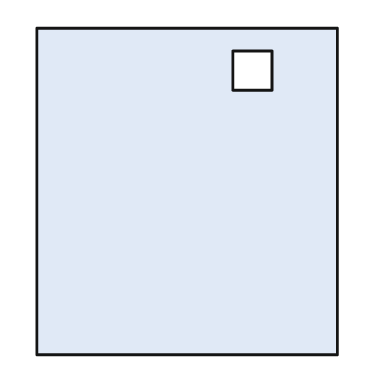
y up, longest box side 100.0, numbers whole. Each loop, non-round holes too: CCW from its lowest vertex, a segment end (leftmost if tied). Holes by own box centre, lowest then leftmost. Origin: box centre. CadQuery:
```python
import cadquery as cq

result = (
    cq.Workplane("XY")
    .moveTo(-46.0, -50.0)
    .lineTo(46.0, -50.0)
    .lineTo(46.0, 50.0)
    .lineTo(-46.0, 50.0)
    .close()
    .moveTo(14.0, 31.0)
    .lineTo(26.0, 31.0)
    .lineTo(26.0, 43.0)
    .lineTo(14.0, 43.0)
    .close()
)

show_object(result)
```